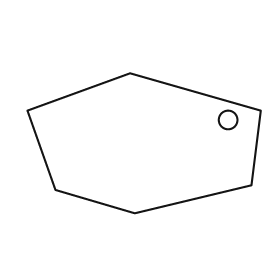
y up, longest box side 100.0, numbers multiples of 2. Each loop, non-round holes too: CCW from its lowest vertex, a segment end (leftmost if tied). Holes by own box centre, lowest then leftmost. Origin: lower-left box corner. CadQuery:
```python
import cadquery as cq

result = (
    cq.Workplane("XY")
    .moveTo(46.0, 0.0)
    .lineTo(96.0, 12.0)
    .lineTo(100.0, 44.0)
    .lineTo(44.0, 60.0)
    .lineTo(0.0, 44.0)
    .lineTo(12.0, 10.0)
    .close()
    .moveTo(86.0, 40.0)
    .circle(4.0)
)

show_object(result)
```